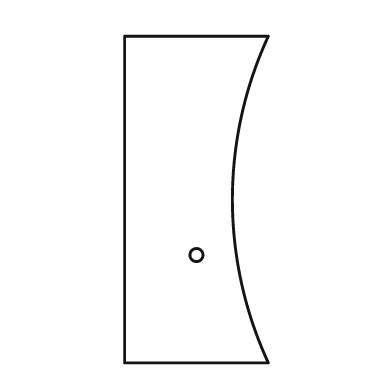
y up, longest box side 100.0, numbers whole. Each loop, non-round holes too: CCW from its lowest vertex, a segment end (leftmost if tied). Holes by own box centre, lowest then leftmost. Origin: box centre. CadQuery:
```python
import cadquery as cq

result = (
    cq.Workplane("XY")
    .moveTo(-22.0, -50.0)
    .lineTo(22.0, -50.0)
    .threePointArc((11.0, 0.0), (22.0, 50.0))
    .lineTo(-22.0, 50.0)
    .close()
    .moveTo(0.0, -17.0)
    .circle(2.0)
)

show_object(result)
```